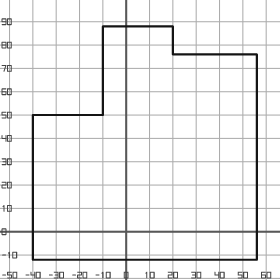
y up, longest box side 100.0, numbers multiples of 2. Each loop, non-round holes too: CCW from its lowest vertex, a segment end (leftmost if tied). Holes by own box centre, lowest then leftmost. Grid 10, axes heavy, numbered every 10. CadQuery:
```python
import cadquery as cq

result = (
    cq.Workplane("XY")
    .moveTo(-40.0, -12.0)
    .lineTo(56.0, -12.0)
    .lineTo(56.0, 76.0)
    .lineTo(20.0, 76.0)
    .lineTo(20.0, 88.0)
    .lineTo(-10.0, 88.0)
    .lineTo(-10.0, 50.0)
    .lineTo(-40.0, 50.0)
    .close()
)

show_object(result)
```